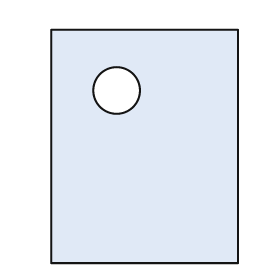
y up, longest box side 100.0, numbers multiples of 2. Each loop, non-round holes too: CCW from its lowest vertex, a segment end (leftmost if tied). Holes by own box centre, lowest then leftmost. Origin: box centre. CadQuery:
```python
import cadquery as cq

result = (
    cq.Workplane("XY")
    .moveTo(-40.0, -50.0)
    .lineTo(40.0, -50.0)
    .lineTo(40.0, 50.0)
    .lineTo(-40.0, 50.0)
    .close()
    .moveTo(-12.0, 24.0)
    .circle(10.0)
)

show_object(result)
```